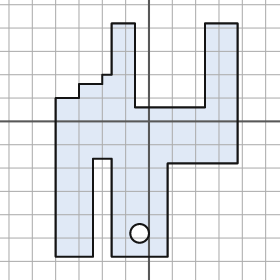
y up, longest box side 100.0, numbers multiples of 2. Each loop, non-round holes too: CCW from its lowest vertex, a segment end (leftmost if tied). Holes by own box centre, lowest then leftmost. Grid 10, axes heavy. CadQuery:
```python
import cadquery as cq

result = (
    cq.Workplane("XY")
    .moveTo(-40.0, -58.0)
    .lineTo(-24.0, -58.0)
    .lineTo(-24.0, -16.0)
    .lineTo(-16.0, -16.0)
    .lineTo(-16.0, -58.0)
    .lineTo(8.0, -58.0)
    .lineTo(8.0, -18.0)
    .lineTo(38.0, -18.0)
    .lineTo(38.0, 42.0)
    .lineTo(24.0, 42.0)
    .lineTo(24.0, 6.0)
    .lineTo(-6.0, 6.0)
    .lineTo(-6.0, 42.0)
    .lineTo(-16.0, 42.0)
    .lineTo(-16.0, 20.0)
    .lineTo(-20.0, 20.0)
    .lineTo(-20.0, 16.0)
    .lineTo(-30.0, 16.0)
    .lineTo(-30.0, 10.0)
    .lineTo(-40.0, 10.0)
    .close()
    .moveTo(-4.0, -48.0)
    .circle(4.0)
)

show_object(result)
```